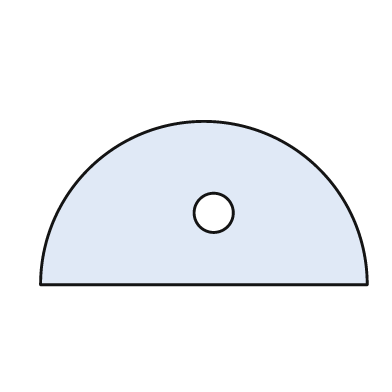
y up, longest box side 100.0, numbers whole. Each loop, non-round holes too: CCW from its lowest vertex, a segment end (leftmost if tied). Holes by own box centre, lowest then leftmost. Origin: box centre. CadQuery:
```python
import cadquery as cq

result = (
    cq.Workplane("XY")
    .moveTo(-50.0, -25.0)
    .lineTo(50.0, -25.0)
    .threePointArc((0.0, 25.0), (-50.0, -25.0))
    .close()
    .moveTo(3.0, -3.0)
    .circle(6.0)
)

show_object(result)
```